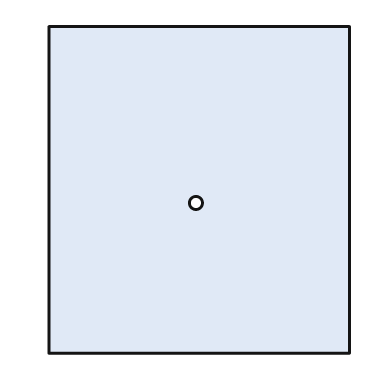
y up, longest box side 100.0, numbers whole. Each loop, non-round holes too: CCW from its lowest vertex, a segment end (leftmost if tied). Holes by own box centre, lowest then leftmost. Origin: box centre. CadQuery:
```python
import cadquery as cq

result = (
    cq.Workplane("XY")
    .moveTo(-46.0, -50.0)
    .lineTo(46.0, -50.0)
    .lineTo(46.0, 50.0)
    .lineTo(-46.0, 50.0)
    .close()
    .moveTo(-1.0, -4.0)
    .circle(2.0)
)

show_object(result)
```